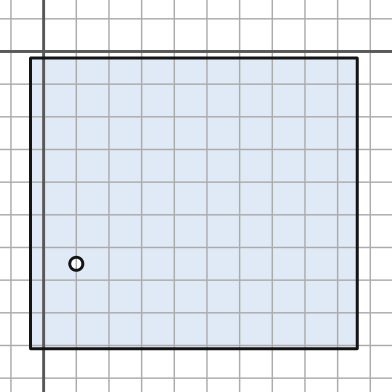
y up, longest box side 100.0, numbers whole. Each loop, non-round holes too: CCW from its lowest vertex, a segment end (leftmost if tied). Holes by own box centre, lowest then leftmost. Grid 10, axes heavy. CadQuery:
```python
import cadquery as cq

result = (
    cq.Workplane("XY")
    .moveTo(-4.0, -91.0)
    .lineTo(96.0, -91.0)
    .lineTo(96.0, -2.0)
    .lineTo(-4.0, -2.0)
    .close()
    .moveTo(10.0, -65.0)
    .circle(2.0)
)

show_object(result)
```